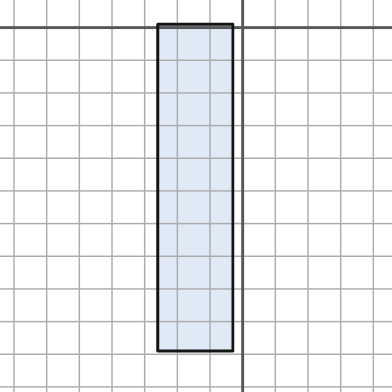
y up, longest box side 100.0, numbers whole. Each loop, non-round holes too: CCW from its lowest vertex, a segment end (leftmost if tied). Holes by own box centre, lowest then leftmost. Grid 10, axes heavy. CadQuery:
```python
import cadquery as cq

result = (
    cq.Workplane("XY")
    .moveTo(-26.0, -99.0)
    .lineTo(-3.0, -99.0)
    .lineTo(-3.0, 1.0)
    .lineTo(-26.0, 1.0)
    .close()
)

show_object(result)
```